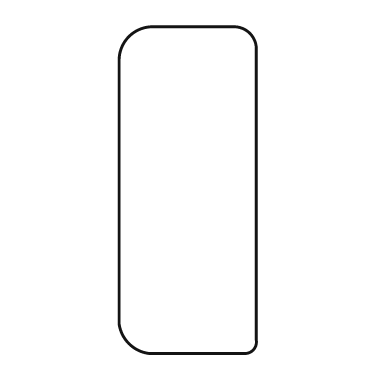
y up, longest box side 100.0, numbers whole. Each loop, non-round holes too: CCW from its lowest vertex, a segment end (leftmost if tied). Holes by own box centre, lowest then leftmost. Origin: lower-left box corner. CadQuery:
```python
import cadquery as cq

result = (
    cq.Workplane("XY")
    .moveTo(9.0, 0.0)
    .lineTo(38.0, 0.0)
    .threePointArc((41.0, 1.0), (42.0, 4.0))
    .lineTo(42.0, 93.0)
    .threePointArc((40.0, 98.0), (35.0, 100.0))
    .lineTo(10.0, 100.0)
    .threePointArc((3.0, 97.0), (0.0, 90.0))
    .lineTo(0.0, 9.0)
    .threePointArc((3.0, 3.0), (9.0, 0.0))
    .close()
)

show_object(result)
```